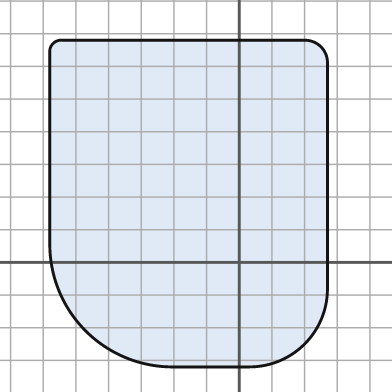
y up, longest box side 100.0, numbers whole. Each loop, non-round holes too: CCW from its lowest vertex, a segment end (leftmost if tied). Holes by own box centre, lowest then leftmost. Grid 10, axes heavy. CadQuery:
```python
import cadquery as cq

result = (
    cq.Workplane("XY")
    .moveTo(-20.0, -32.0)
    .lineTo(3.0, -32.0)
    .threePointArc((20.0, -25.0), (27.0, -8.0))
    .lineTo(27.0, 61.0)
    .threePointArc((25.0, 66.0), (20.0, 68.0))
    .lineTo(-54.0, 68.0)
    .threePointArc((-57.0, 67.0), (-58.0, 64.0))
    .lineTo(-58.0, 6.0)
    .threePointArc((-47.0, -21.0), (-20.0, -32.0))
    .close()
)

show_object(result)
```